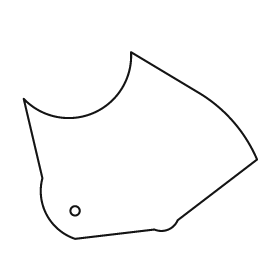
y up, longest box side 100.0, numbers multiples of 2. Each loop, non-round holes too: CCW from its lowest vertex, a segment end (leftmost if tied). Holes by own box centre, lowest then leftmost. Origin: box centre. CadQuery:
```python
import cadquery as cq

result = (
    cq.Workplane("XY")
    .moveTo(-28.0, -40.0)
    .lineTo(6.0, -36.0)
    .threePointArc((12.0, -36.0), (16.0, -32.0))
    .lineTo(50.0, -6.0)
    .threePointArc((40.0, 10.0), (26.0, 22.0))
    .lineTo(-4.0, 40.0)
    .threePointArc((-20.0, 14.0), (-50.0, 20.0))
    .lineTo(-42.0, -14.0)
    .threePointArc((-40.0, -30.0), (-28.0, -40.0))
    .close()
    .moveTo(-28.0, -28.0)
    .circle(2.0)
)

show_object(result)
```